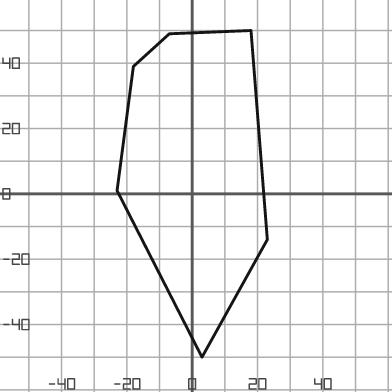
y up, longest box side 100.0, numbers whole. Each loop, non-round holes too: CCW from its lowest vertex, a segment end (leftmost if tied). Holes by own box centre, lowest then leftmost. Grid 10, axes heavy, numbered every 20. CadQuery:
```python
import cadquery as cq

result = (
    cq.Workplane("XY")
    .moveTo(3.0, -50.0)
    .lineTo(23.0, -14.0)
    .lineTo(18.0, 50.0)
    .lineTo(-7.0, 49.0)
    .lineTo(-18.0, 39.0)
    .lineTo(-23.0, 1.0)
    .close()
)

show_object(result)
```